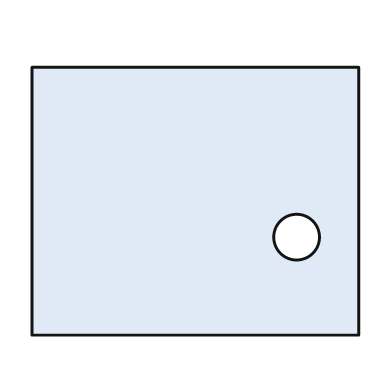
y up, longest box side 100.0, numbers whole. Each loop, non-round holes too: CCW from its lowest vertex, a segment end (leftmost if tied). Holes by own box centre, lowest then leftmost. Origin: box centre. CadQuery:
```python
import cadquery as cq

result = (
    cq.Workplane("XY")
    .moveTo(-50.0, -41.0)
    .lineTo(50.0, -41.0)
    .lineTo(50.0, 41.0)
    .lineTo(-50.0, 41.0)
    .close()
    .moveTo(31.0, -11.0)
    .circle(7.0)
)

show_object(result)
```